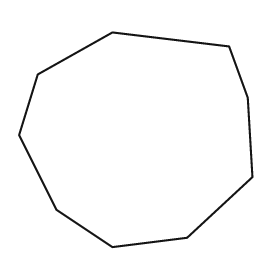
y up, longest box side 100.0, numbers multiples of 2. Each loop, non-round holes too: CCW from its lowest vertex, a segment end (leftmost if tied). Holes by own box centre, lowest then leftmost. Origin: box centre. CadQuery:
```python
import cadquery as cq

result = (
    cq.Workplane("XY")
    .moveTo(-10.0, -46.0)
    .lineTo(22.0, -42.0)
    .lineTo(50.0, -16.0)
    .lineTo(48.0, 18.0)
    .lineTo(40.0, 40.0)
    .lineTo(-10.0, 46.0)
    .lineTo(-42.0, 28.0)
    .lineTo(-50.0, 2.0)
    .lineTo(-34.0, -30.0)
    .close()
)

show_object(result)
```